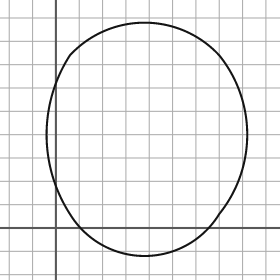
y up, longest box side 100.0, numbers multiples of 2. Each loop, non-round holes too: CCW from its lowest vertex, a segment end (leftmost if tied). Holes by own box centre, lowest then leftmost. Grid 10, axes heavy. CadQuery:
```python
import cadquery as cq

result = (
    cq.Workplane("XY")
    .moveTo(6.0, 6.0)
    .threePointArc((38.0, -12.0), (70.0, 6.0))
    .threePointArc((82.0, 40.0), (70.0, 74.0))
    .threePointArc((38.0, 88.0), (6.0, 74.0))
    .threePointArc((-4.0, 40.0), (6.0, 6.0))
    .close()
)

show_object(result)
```